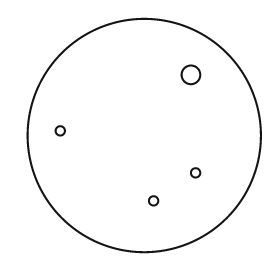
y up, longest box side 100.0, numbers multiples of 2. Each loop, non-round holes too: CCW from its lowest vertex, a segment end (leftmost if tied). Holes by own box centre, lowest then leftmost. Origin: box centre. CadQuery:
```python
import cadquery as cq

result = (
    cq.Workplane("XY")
    .moveTo(0.0, 0.0)
    .circle(50.0)
    .moveTo(4.0, -28.0)
    .circle(2.0)
    .moveTo(22.0, -16.0)
    .circle(2.0)
    .moveTo(-36.0, 2.0)
    .circle(2.0)
    .moveTo(20.0, 26.0)
    .circle(4.0)
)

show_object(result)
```